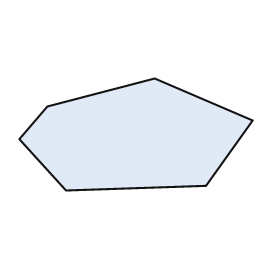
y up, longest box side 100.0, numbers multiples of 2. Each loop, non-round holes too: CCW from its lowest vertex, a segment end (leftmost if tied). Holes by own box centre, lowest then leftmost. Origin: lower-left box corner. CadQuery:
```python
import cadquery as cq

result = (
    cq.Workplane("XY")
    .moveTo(20.0, 0.0)
    .lineTo(80.0, 2.0)
    .lineTo(100.0, 30.0)
    .lineTo(58.0, 48.0)
    .lineTo(12.0, 36.0)
    .lineTo(0.0, 22.0)
    .close()
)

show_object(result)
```